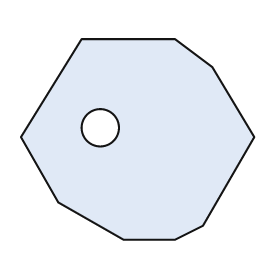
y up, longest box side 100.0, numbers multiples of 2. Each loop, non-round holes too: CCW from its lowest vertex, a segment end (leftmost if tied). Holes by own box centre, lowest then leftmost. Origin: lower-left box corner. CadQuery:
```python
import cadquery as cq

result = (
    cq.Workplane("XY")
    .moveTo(44.0, 0.0)
    .lineTo(66.0, 0.0)
    .lineTo(78.0, 6.0)
    .lineTo(100.0, 44.0)
    .lineTo(82.0, 74.0)
    .lineTo(66.0, 86.0)
    .lineTo(26.0, 86.0)
    .lineTo(0.0, 44.0)
    .lineTo(16.0, 16.0)
    .close()
    .moveTo(34.0, 48.0)
    .circle(8.0)
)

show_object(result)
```